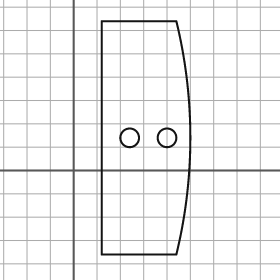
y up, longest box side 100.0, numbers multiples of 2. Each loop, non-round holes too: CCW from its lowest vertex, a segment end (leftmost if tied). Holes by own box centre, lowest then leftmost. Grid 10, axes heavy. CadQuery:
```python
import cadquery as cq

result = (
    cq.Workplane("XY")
    .moveTo(12.0, -36.0)
    .lineTo(44.0, -36.0)
    .threePointArc((50.0, 14.0), (44.0, 64.0))
    .lineTo(12.0, 64.0)
    .close()
    .moveTo(24.0, 14.0)
    .circle(4.0)
    .moveTo(40.0, 14.0)
    .circle(4.0)
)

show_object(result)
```